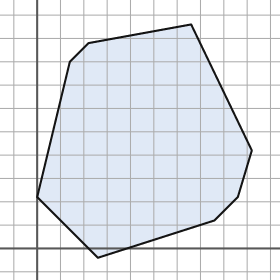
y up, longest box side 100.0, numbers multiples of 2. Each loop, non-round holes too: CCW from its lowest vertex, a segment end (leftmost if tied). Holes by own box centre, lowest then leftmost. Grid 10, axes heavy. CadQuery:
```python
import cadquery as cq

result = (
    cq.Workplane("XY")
    .moveTo(26.0, -4.0)
    .lineTo(76.0, 12.0)
    .lineTo(86.0, 22.0)
    .lineTo(92.0, 42.0)
    .lineTo(66.0, 96.0)
    .lineTo(22.0, 88.0)
    .lineTo(14.0, 80.0)
    .lineTo(0.0, 22.0)
    .close()
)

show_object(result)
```